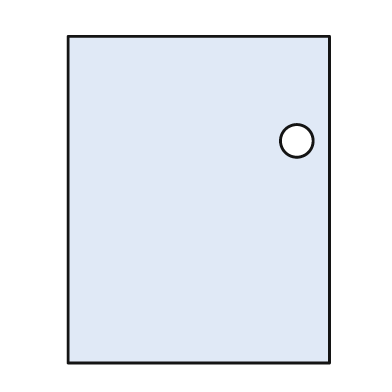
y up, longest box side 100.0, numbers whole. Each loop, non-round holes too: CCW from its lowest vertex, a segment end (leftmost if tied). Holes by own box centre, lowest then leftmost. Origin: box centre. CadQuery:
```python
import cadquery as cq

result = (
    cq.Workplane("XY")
    .moveTo(-40.0, -50.0)
    .lineTo(40.0, -50.0)
    .lineTo(40.0, 50.0)
    .lineTo(-40.0, 50.0)
    .close()
    .moveTo(30.0, 18.0)
    .circle(5.0)
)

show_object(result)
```